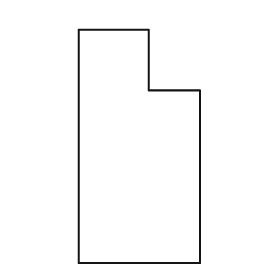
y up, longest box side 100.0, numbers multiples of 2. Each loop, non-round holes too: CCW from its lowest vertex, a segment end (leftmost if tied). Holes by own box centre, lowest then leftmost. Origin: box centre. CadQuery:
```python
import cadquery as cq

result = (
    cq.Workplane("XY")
    .moveTo(-26.0, -50.0)
    .lineTo(26.0, -50.0)
    .lineTo(26.0, 24.0)
    .lineTo(4.0, 24.0)
    .lineTo(4.0, 50.0)
    .lineTo(-26.0, 50.0)
    .close()
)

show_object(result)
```